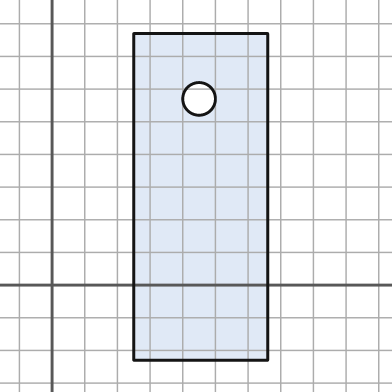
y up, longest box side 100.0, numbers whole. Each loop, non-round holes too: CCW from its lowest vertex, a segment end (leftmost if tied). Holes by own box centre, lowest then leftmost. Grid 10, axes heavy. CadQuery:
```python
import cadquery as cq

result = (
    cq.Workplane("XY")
    .moveTo(25.0, -23.0)
    .lineTo(66.0, -23.0)
    .lineTo(66.0, 77.0)
    .lineTo(25.0, 77.0)
    .close()
    .moveTo(45.0, 57.0)
    .circle(5.0)
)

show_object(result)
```